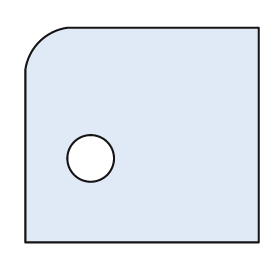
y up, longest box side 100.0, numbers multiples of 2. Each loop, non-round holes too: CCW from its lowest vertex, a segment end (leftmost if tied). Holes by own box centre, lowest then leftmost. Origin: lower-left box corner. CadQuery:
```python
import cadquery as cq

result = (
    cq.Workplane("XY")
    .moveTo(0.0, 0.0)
    .lineTo(100.0, 0.0)
    .lineTo(100.0, 92.0)
    .lineTo(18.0, 92.0)
    .threePointArc((6.0, 86.0), (0.0, 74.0))
    .close()
    .moveTo(28.0, 36.0)
    .circle(10.0)
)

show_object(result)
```